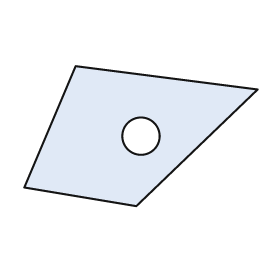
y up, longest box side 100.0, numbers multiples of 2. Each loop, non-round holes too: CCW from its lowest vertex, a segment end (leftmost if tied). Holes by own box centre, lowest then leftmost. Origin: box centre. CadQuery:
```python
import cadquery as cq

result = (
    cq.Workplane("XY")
    .moveTo(-2.0, -30.0)
    .lineTo(50.0, 20.0)
    .lineTo(-28.0, 30.0)
    .lineTo(-50.0, -22.0)
    .close()
    .moveTo(0.0, 0.0)
    .circle(8.0)
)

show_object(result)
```